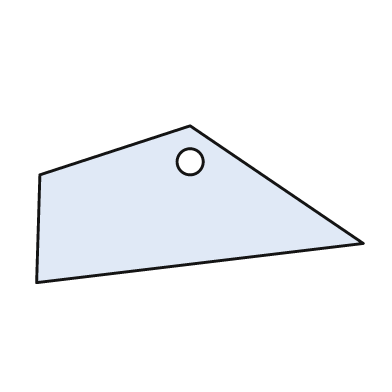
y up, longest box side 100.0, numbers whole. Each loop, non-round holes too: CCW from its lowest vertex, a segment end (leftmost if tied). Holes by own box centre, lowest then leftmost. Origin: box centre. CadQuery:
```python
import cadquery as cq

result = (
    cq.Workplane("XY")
    .moveTo(-50.0, -24.0)
    .lineTo(50.0, -12.0)
    .lineTo(-3.0, 24.0)
    .lineTo(-49.0, 9.0)
    .close()
    .moveTo(-3.0, 13.0)
    .circle(4.0)
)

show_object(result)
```